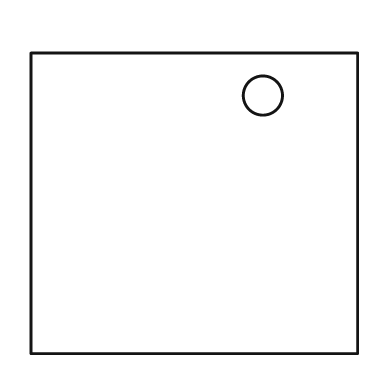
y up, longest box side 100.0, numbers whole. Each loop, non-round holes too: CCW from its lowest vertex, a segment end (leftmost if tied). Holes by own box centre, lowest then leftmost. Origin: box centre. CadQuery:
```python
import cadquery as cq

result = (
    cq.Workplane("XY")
    .moveTo(-50.0, -46.0)
    .lineTo(50.0, -46.0)
    .lineTo(50.0, 46.0)
    .lineTo(-50.0, 46.0)
    .close()
    .moveTo(21.0, 33.0)
    .circle(6.0)
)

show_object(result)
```